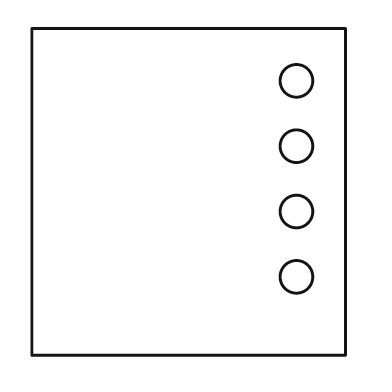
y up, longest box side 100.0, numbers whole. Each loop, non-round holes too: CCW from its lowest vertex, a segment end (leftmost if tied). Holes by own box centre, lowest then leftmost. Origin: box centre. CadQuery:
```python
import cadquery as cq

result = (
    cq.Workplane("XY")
    .moveTo(-48.0, -50.0)
    .lineTo(48.0, -50.0)
    .lineTo(48.0, 50.0)
    .lineTo(-48.0, 50.0)
    .close()
    .moveTo(33.0, -26.0)
    .circle(5.0)
    .moveTo(33.0, -6.0)
    .circle(5.0)
    .moveTo(33.0, 14.0)
    .circle(5.0)
    .moveTo(33.0, 34.0)
    .circle(5.0)
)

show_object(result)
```